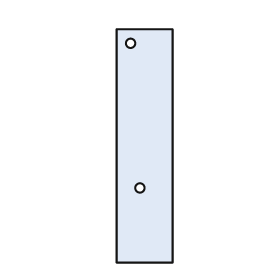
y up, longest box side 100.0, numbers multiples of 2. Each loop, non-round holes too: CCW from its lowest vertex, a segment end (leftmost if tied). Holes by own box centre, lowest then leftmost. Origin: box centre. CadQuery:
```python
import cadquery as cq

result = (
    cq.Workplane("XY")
    .moveTo(-12.0, -50.0)
    .lineTo(12.0, -50.0)
    .lineTo(12.0, 50.0)
    .lineTo(-12.0, 50.0)
    .close()
    .moveTo(-2.0, -18.0)
    .circle(2.0)
    .moveTo(-6.0, 44.0)
    .circle(2.0)
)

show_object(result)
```